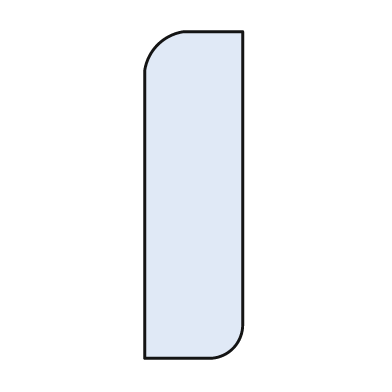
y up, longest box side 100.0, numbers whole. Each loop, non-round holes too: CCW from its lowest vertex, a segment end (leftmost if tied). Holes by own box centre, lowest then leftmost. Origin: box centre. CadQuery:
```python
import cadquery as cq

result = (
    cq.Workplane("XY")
    .moveTo(-15.0, -50.0)
    .lineTo(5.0, -50.0)
    .threePointArc((12.0, -47.0), (15.0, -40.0))
    .lineTo(15.0, 50.0)
    .lineTo(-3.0, 50.0)
    .threePointArc((-11.0, 46.0), (-15.0, 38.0))
    .close()
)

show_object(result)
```